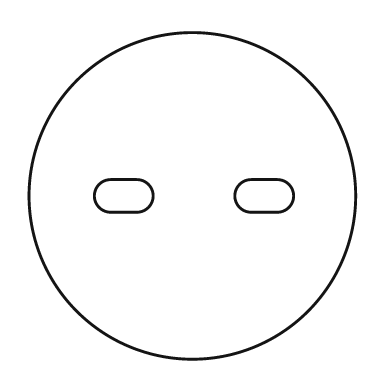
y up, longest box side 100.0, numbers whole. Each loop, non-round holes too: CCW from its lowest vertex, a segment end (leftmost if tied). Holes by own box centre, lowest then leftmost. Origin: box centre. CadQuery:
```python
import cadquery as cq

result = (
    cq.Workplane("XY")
    .moveTo(0.0, 0.0)
    .circle(50.0)
    .moveTo(-25.0, -5.0)
    .lineTo(-17.0, -5.0)
    .threePointArc((-12.0, 0.0), (-17.0, 5.0))
    .lineTo(-25.0, 5.0)
    .threePointArc((-30.0, 0.0), (-25.0, -5.0))
    .close()
    .moveTo(18.0, -5.0)
    .lineTo(26.0, -5.0)
    .threePointArc((31.0, 0.0), (26.0, 5.0))
    .lineTo(18.0, 5.0)
    .threePointArc((13.0, 0.0), (18.0, -5.0))
    .close()
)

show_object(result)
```